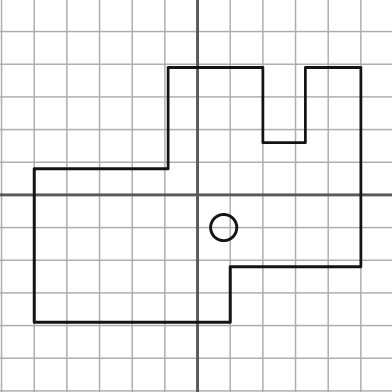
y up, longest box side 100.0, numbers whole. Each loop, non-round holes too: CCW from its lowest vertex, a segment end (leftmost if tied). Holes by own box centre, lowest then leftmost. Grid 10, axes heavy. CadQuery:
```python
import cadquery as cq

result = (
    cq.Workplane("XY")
    .moveTo(-50.0, -39.0)
    .lineTo(10.0, -39.0)
    .lineTo(10.0, -22.0)
    .lineTo(50.0, -22.0)
    .lineTo(50.0, 39.0)
    .lineTo(33.0, 39.0)
    .lineTo(33.0, 16.0)
    .lineTo(20.0, 16.0)
    .lineTo(20.0, 39.0)
    .lineTo(-9.0, 39.0)
    .lineTo(-9.0, 8.0)
    .lineTo(-50.0, 8.0)
    .close()
    .moveTo(8.0, -10.0)
    .circle(4.0)
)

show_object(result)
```